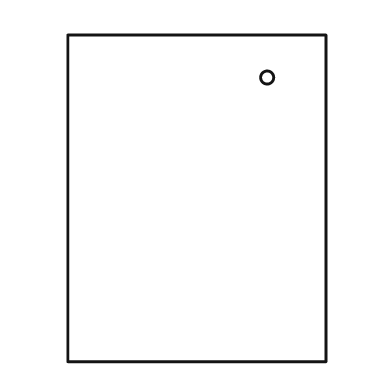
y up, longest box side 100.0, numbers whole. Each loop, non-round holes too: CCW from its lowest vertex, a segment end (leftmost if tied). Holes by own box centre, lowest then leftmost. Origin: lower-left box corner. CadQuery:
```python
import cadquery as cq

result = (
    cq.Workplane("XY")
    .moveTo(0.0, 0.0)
    .lineTo(79.0, 0.0)
    .lineTo(79.0, 100.0)
    .lineTo(0.0, 100.0)
    .close()
    .moveTo(61.0, 87.0)
    .circle(2.0)
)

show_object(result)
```